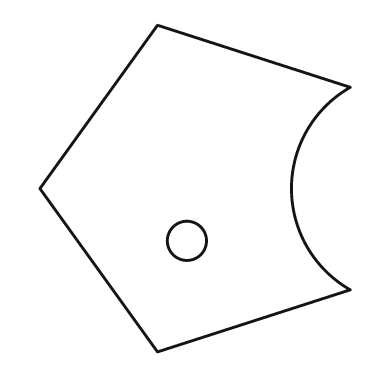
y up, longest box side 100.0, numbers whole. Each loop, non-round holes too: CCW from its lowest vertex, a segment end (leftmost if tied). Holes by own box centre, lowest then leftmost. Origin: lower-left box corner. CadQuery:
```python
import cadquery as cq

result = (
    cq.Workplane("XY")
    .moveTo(36.0, 0.0)
    .lineTo(95.0, 19.0)
    .threePointArc((77.0, 50.0), (95.0, 81.0))
    .lineTo(36.0, 100.0)
    .lineTo(0.0, 50.0)
    .close()
    .moveTo(45.0, 34.0)
    .circle(6.0)
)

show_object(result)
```